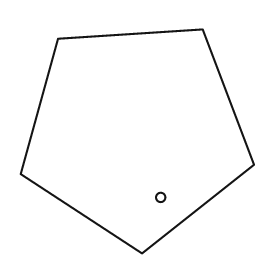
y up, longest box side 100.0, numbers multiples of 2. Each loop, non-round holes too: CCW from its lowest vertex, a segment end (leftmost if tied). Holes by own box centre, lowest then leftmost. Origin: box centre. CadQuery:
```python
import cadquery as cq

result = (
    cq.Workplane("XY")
    .moveTo(2.0, -48.0)
    .lineTo(50.0, -10.0)
    .lineTo(28.0, 48.0)
    .lineTo(-34.0, 44.0)
    .lineTo(-50.0, -14.0)
    .close()
    .moveTo(10.0, -24.0)
    .circle(2.0)
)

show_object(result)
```